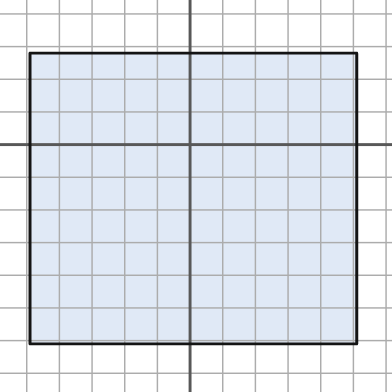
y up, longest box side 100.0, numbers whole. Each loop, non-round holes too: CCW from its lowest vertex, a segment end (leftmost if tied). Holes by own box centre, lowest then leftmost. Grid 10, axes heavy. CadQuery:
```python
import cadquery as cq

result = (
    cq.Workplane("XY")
    .moveTo(-49.0, -61.0)
    .lineTo(51.0, -61.0)
    .lineTo(51.0, 28.0)
    .lineTo(-49.0, 28.0)
    .close()
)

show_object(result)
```